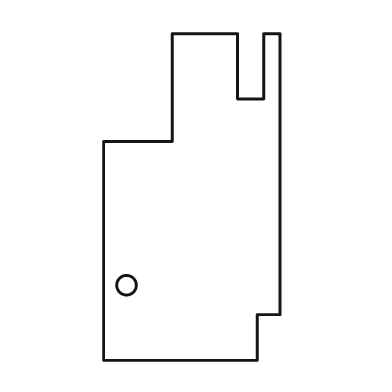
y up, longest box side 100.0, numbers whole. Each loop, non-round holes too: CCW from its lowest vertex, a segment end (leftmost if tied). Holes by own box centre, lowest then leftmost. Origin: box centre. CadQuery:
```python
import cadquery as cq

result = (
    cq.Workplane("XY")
    .moveTo(-27.0, -50.0)
    .lineTo(20.0, -50.0)
    .lineTo(20.0, -36.0)
    .lineTo(27.0, -36.0)
    .lineTo(27.0, 50.0)
    .lineTo(22.0, 50.0)
    .lineTo(22.0, 30.0)
    .lineTo(14.0, 30.0)
    .lineTo(14.0, 50.0)
    .lineTo(-6.0, 50.0)
    .lineTo(-6.0, 17.0)
    .lineTo(-27.0, 17.0)
    .close()
    .moveTo(-20.0, -27.0)
    .circle(3.0)
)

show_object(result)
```